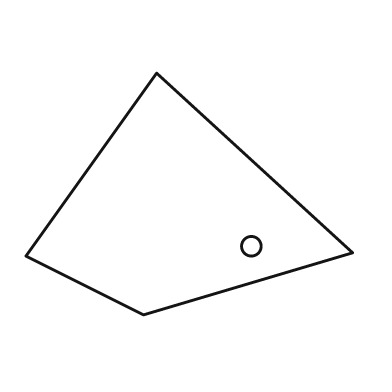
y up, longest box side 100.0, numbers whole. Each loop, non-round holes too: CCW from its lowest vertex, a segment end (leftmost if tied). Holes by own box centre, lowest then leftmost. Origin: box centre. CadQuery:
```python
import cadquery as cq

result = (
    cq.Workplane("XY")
    .moveTo(-14.0, -37.0)
    .lineTo(50.0, -18.0)
    .lineTo(-10.0, 37.0)
    .lineTo(-50.0, -19.0)
    .close()
    .moveTo(19.0, -16.0)
    .circle(3.0)
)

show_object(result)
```